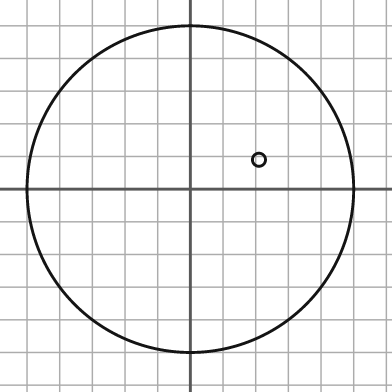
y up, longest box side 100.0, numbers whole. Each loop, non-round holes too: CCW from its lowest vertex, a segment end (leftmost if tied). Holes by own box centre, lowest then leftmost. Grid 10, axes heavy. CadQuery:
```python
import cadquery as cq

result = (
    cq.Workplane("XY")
    .moveTo(0.0, 0.0)
    .circle(50.0)
    .moveTo(21.0, 9.0)
    .circle(2.0)
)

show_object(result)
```